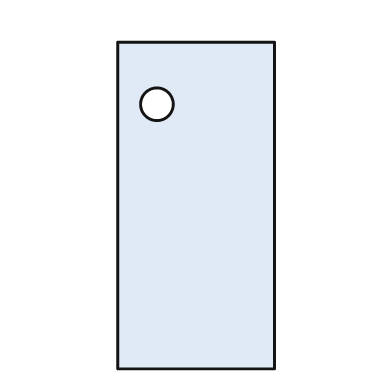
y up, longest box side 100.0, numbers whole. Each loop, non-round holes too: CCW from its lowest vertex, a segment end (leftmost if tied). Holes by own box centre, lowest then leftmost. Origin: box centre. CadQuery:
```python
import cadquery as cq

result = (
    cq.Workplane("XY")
    .moveTo(-24.0, -50.0)
    .lineTo(24.0, -50.0)
    .lineTo(24.0, 50.0)
    .lineTo(-24.0, 50.0)
    .close()
    .moveTo(-12.0, 31.0)
    .circle(5.0)
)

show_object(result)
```